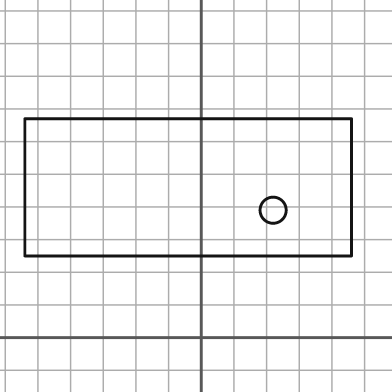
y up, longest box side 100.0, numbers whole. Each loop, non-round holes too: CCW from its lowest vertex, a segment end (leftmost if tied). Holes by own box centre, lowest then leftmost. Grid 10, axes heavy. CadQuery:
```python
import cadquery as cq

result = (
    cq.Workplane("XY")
    .moveTo(-54.0, 25.0)
    .lineTo(46.0, 25.0)
    .lineTo(46.0, 67.0)
    .lineTo(-54.0, 67.0)
    .close()
    .moveTo(22.0, 39.0)
    .circle(4.0)
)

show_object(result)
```